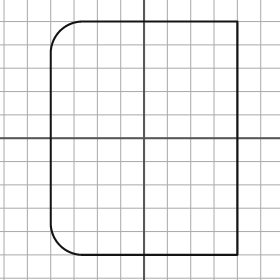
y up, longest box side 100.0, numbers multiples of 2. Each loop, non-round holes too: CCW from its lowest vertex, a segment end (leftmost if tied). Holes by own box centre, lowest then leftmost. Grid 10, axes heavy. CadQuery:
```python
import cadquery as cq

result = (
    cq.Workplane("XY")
    .moveTo(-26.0, -50.0)
    .lineTo(40.0, -50.0)
    .lineTo(40.0, 50.0)
    .lineTo(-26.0, 50.0)
    .threePointArc((-36.0, 46.0), (-40.0, 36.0))
    .lineTo(-40.0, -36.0)
    .threePointArc((-36.0, -46.0), (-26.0, -50.0))
    .close()
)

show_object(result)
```